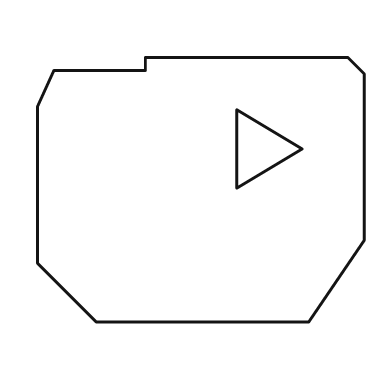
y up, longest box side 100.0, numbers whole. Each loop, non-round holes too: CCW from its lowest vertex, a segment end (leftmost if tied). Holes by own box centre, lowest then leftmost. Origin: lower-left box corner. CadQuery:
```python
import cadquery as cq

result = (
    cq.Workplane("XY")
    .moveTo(18.0, 0.0)
    .lineTo(83.0, 0.0)
    .lineTo(100.0, 25.0)
    .lineTo(100.0, 76.0)
    .lineTo(95.0, 81.0)
    .lineTo(33.0, 81.0)
    .lineTo(33.0, 77.0)
    .lineTo(5.0, 77.0)
    .lineTo(0.0, 66.0)
    .lineTo(0.0, 18.0)
    .close()
    .moveTo(61.0, 41.0)
    .lineTo(81.0, 53.0)
    .lineTo(61.0, 65.0)
    .close()
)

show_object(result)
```